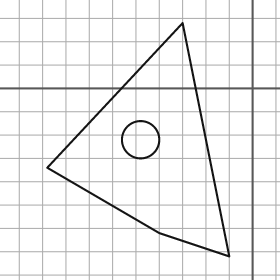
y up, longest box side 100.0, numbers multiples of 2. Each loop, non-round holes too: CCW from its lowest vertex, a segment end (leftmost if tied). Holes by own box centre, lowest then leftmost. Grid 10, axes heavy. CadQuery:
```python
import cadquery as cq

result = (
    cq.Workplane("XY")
    .moveTo(-10.0, -72.0)
    .lineTo(-30.0, 28.0)
    .lineTo(-88.0, -34.0)
    .lineTo(-40.0, -62.0)
    .close()
    .moveTo(-48.0, -22.0)
    .circle(8.0)
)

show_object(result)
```